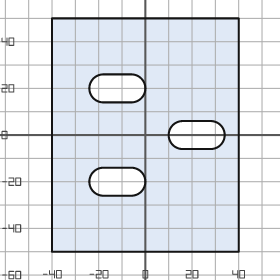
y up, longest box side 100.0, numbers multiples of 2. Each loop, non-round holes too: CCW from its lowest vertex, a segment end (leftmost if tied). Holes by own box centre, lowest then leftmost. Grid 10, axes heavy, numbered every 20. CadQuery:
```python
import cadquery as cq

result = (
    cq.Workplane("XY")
    .moveTo(-40.0, -50.0)
    .lineTo(40.0, -50.0)
    .lineTo(40.0, 50.0)
    .lineTo(-40.0, 50.0)
    .close()
    .moveTo(-18.0, -26.0)
    .lineTo(-6.0, -26.0)
    .threePointArc((0.0, -20.0), (-6.0, -14.0))
    .lineTo(-18.0, -14.0)
    .threePointArc((-24.0, -20.0), (-18.0, -26.0))
    .close()
    .moveTo(16.0, -6.0)
    .lineTo(28.0, -6.0)
    .threePointArc((34.0, 0.0), (28.0, 6.0))
    .lineTo(16.0, 6.0)
    .threePointArc((10.0, 0.0), (16.0, -6.0))
    .close()
    .moveTo(-18.0, 14.0)
    .lineTo(-6.0, 14.0)
    .threePointArc((0.0, 20.0), (-6.0, 26.0))
    .lineTo(-18.0, 26.0)
    .threePointArc((-24.0, 20.0), (-18.0, 14.0))
    .close()
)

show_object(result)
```